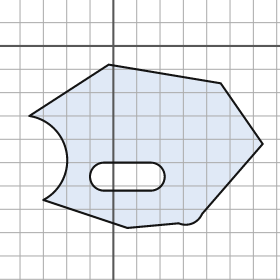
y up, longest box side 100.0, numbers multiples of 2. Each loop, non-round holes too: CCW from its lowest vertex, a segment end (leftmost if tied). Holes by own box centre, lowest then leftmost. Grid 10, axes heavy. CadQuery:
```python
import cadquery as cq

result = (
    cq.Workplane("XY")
    .moveTo(6.0, -78.0)
    .lineTo(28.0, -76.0)
    .threePointArc((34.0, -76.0), (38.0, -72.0))
    .lineTo(64.0, -42.0)
    .lineTo(46.0, -16.0)
    .lineTo(-2.0, -8.0)
    .lineTo(-36.0, -30.0)
    .threePointArc((-20.0, -46.0), (-30.0, -66.0))
    .close()
    .moveTo(-4.0, -62.0)
    .lineTo(16.0, -62.0)
    .threePointArc((22.0, -56.0), (16.0, -50.0))
    .lineTo(-4.0, -50.0)
    .threePointArc((-10.0, -56.0), (-4.0, -62.0))
    .close()
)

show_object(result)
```